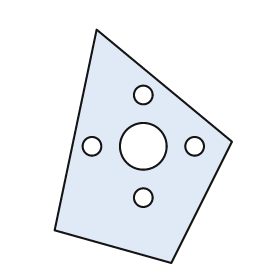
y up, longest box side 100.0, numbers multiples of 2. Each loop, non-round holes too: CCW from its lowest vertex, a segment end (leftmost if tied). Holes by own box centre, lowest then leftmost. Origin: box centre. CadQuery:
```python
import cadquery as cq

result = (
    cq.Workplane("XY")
    .moveTo(12.0, -50.0)
    .lineTo(38.0, 2.0)
    .lineTo(-20.0, 50.0)
    .lineTo(-38.0, -36.0)
    .close()
    .moveTo(0.0, -22.0)
    .circle(4.0)
    .moveTo(-22.0, 0.0)
    .circle(4.0)
    .moveTo(0.0, 0.0)
    .circle(10.0)
    .moveTo(22.0, 0.0)
    .circle(4.0)
    .moveTo(0.0, 22.0)
    .circle(4.0)
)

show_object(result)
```